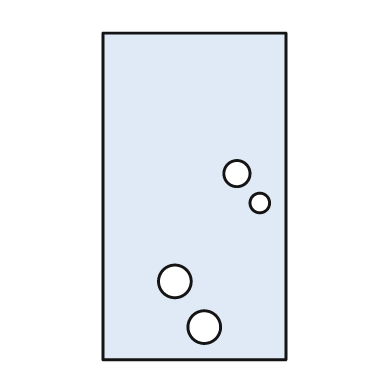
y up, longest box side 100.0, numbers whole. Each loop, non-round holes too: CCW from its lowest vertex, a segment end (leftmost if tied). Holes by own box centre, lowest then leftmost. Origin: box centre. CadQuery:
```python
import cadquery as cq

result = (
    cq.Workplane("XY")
    .moveTo(-28.0, -50.0)
    .lineTo(28.0, -50.0)
    .lineTo(28.0, 50.0)
    .lineTo(-28.0, 50.0)
    .close()
    .moveTo(3.0, -40.0)
    .circle(5.0)
    .moveTo(-6.0, -26.0)
    .circle(5.0)
    .moveTo(20.0, -2.0)
    .circle(3.0)
    .moveTo(13.0, 7.0)
    .circle(4.0)
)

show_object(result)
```